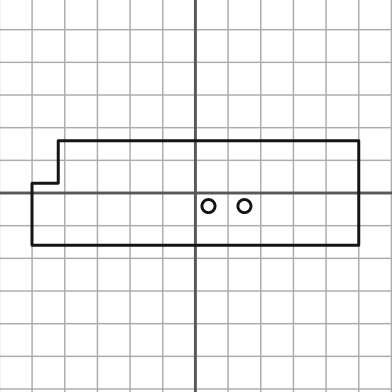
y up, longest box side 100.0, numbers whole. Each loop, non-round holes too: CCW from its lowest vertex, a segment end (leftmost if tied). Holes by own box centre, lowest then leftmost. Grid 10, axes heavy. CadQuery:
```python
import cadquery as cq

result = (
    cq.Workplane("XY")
    .moveTo(-50.0, -16.0)
    .lineTo(50.0, -16.0)
    .lineTo(50.0, 16.0)
    .lineTo(-42.0, 16.0)
    .lineTo(-42.0, 3.0)
    .lineTo(-50.0, 3.0)
    .close()
    .moveTo(4.0, -4.0)
    .circle(2.0)
    .moveTo(15.0, -4.0)
    .circle(2.0)
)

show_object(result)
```